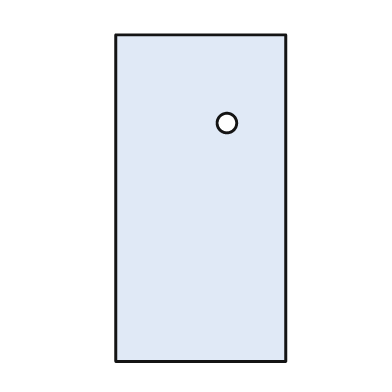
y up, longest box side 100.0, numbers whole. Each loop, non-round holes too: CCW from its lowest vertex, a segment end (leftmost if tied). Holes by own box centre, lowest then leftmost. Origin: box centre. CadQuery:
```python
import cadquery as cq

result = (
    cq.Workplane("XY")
    .moveTo(-26.0, -50.0)
    .lineTo(26.0, -50.0)
    .lineTo(26.0, 50.0)
    .lineTo(-26.0, 50.0)
    .close()
    .moveTo(8.0, 23.0)
    .circle(3.0)
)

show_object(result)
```